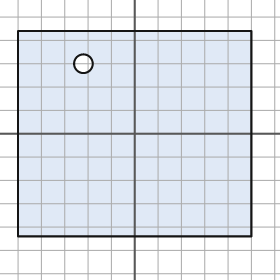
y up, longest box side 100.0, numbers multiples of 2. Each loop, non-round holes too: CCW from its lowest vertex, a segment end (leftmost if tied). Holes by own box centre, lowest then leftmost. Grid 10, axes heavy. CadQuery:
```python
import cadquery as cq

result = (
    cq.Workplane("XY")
    .moveTo(-50.0, -44.0)
    .lineTo(50.0, -44.0)
    .lineTo(50.0, 44.0)
    .lineTo(-50.0, 44.0)
    .close()
    .moveTo(-22.0, 30.0)
    .circle(4.0)
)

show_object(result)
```